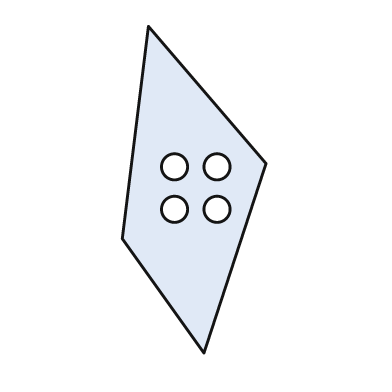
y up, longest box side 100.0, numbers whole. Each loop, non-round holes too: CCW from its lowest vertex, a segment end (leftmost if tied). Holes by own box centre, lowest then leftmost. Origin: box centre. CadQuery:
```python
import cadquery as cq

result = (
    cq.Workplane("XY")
    .moveTo(3.0, -50.0)
    .lineTo(22.0, 8.0)
    .lineTo(-14.0, 50.0)
    .lineTo(-22.0, -15.0)
    .close()
    .moveTo(-6.0, -6.0)
    .circle(4.0)
    .moveTo(7.0, -6.0)
    .circle(4.0)
    .moveTo(-6.0, 7.0)
    .circle(4.0)
    .moveTo(7.0, 7.0)
    .circle(4.0)
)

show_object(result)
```